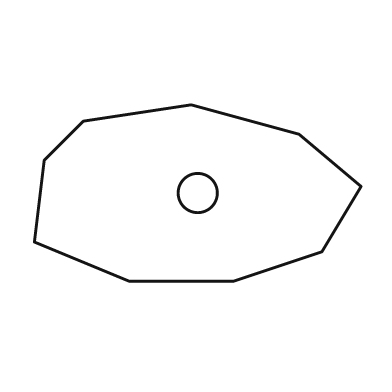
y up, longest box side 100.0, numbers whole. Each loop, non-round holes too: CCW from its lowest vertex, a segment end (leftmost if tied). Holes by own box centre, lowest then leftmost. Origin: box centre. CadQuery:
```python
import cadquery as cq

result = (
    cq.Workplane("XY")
    .moveTo(-21.0, -27.0)
    .lineTo(11.0, -27.0)
    .lineTo(38.0, -18.0)
    .lineTo(50.0, 2.0)
    .lineTo(31.0, 18.0)
    .lineTo(-2.0, 27.0)
    .lineTo(-35.0, 22.0)
    .lineTo(-47.0, 10.0)
    .lineTo(-50.0, -15.0)
    .close()
    .moveTo(0.0, 0.0)
    .circle(6.0)
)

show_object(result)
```